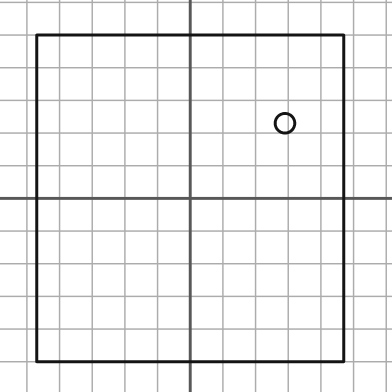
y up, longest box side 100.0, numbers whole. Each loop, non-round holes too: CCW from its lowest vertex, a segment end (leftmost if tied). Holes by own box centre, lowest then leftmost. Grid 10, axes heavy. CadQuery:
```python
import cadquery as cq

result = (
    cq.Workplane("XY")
    .moveTo(-47.0, -50.0)
    .lineTo(47.0, -50.0)
    .lineTo(47.0, 50.0)
    .lineTo(-47.0, 50.0)
    .close()
    .moveTo(29.0, 23.0)
    .circle(3.0)
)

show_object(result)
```